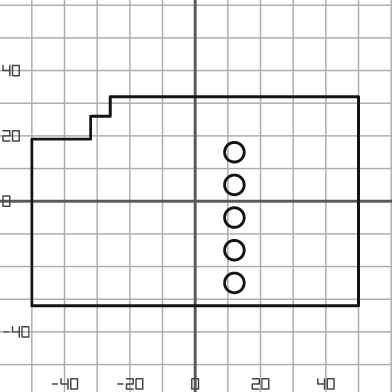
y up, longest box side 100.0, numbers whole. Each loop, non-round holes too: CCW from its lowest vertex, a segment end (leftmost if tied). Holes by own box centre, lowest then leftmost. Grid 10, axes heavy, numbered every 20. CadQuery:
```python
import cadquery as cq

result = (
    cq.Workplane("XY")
    .moveTo(-50.0, -32.0)
    .lineTo(50.0, -32.0)
    .lineTo(50.0, 32.0)
    .lineTo(-26.0, 32.0)
    .lineTo(-26.0, 26.0)
    .lineTo(-32.0, 26.0)
    .lineTo(-32.0, 19.0)
    .lineTo(-50.0, 19.0)
    .close()
    .moveTo(12.0, -25.0)
    .circle(3.0)
    .moveTo(12.0, -15.0)
    .circle(3.0)
    .moveTo(12.0, -5.0)
    .circle(3.0)
    .moveTo(12.0, 5.0)
    .circle(3.0)
    .moveTo(12.0, 15.0)
    .circle(3.0)
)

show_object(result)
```